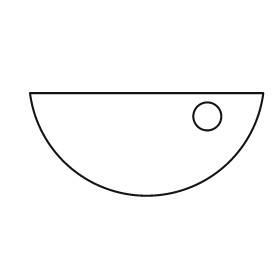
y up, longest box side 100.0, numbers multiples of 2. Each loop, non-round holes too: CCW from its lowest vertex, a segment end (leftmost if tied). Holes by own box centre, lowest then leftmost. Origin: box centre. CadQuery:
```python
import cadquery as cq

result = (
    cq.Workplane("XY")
    .moveTo(-50.0, 22.0)
    .threePointArc((0.0, -22.0), (50.0, 22.0))
    .close()
    .moveTo(26.0, 12.0)
    .circle(6.0)
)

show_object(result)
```